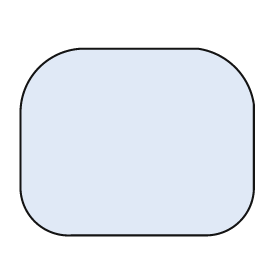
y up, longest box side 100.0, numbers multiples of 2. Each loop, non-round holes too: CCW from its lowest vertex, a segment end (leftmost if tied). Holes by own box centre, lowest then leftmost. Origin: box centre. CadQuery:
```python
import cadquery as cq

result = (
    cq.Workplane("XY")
    .moveTo(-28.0, -40.0)
    .lineTo(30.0, -40.0)
    .threePointArc((44.0, -34.0), (50.0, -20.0))
    .lineTo(50.0, 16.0)
    .threePointArc((42.0, 32.0), (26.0, 40.0))
    .lineTo(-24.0, 40.0)
    .threePointArc((-42.0, 32.0), (-50.0, 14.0))
    .lineTo(-50.0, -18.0)
    .threePointArc((-44.0, -34.0), (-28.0, -40.0))
    .close()
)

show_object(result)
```